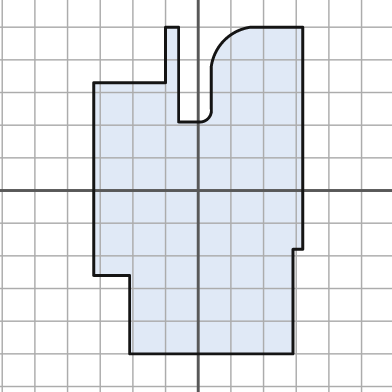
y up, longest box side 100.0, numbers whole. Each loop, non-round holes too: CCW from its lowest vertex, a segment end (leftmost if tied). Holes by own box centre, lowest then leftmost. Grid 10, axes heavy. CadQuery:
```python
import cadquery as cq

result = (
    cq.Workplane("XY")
    .moveTo(-21.0, -50.0)
    .lineTo(29.0, -50.0)
    .lineTo(29.0, -18.0)
    .lineTo(32.0, -18.0)
    .lineTo(32.0, 50.0)
    .lineTo(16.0, 50.0)
    .threePointArc((8.0, 46.0), (4.0, 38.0))
    .lineTo(4.0, 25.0)
    .threePointArc((3.0, 22.0), (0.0, 21.0))
    .lineTo(-6.0, 21.0)
    .lineTo(-6.0, 50.0)
    .lineTo(-10.0, 50.0)
    .lineTo(-10.0, 33.0)
    .lineTo(-32.0, 33.0)
    .lineTo(-32.0, -26.0)
    .lineTo(-21.0, -26.0)
    .close()
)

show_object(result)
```